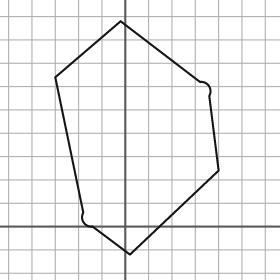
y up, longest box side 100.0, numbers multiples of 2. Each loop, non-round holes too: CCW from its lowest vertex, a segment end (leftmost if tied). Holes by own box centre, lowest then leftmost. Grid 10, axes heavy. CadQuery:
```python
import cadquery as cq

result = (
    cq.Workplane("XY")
    .moveTo(2.0, -12.0)
    .lineTo(40.0, 24.0)
    .lineTo(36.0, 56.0)
    .threePointArc((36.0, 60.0), (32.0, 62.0))
    .lineTo(-2.0, 88.0)
    .lineTo(-30.0, 64.0)
    .lineTo(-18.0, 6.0)
    .threePointArc((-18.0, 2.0), (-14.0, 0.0))
    .close()
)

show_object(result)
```